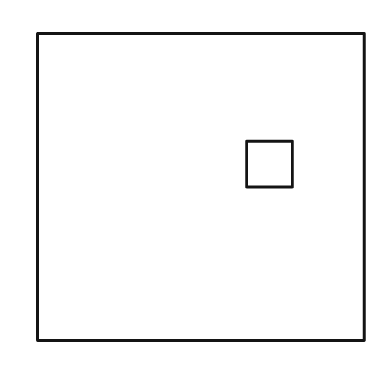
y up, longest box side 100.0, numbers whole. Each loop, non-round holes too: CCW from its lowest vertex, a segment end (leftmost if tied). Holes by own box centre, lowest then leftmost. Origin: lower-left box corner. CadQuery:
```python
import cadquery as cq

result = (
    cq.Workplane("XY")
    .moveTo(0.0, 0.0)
    .lineTo(100.0, 0.0)
    .lineTo(100.0, 94.0)
    .lineTo(0.0, 94.0)
    .close()
    .moveTo(64.0, 47.0)
    .lineTo(78.0, 47.0)
    .lineTo(78.0, 61.0)
    .lineTo(64.0, 61.0)
    .close()
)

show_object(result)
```